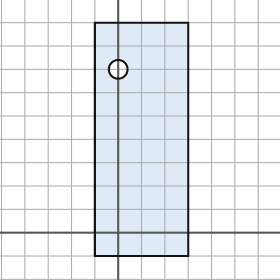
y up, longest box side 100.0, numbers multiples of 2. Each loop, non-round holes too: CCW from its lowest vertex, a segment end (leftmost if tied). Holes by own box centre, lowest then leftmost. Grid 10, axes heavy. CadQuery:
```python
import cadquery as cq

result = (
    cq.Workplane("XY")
    .moveTo(-10.0, -10.0)
    .lineTo(30.0, -10.0)
    .lineTo(30.0, 90.0)
    .lineTo(-10.0, 90.0)
    .close()
    .moveTo(0.0, 70.0)
    .circle(4.0)
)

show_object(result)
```